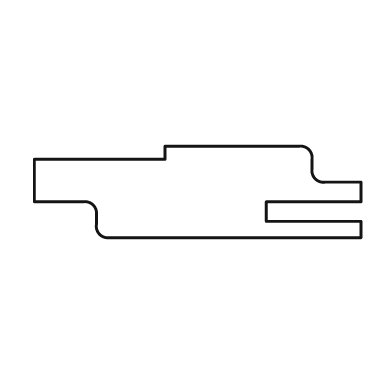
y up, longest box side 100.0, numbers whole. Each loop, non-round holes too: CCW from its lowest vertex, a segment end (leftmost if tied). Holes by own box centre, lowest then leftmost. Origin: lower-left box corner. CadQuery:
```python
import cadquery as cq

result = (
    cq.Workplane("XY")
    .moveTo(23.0, 0.0)
    .lineTo(100.0, 0.0)
    .lineTo(100.0, 5.0)
    .lineTo(71.0, 5.0)
    .lineTo(71.0, 11.0)
    .lineTo(100.0, 11.0)
    .lineTo(100.0, 17.0)
    .lineTo(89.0, 17.0)
    .threePointArc((86.0, 18.0), (85.0, 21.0))
    .lineTo(85.0, 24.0)
    .threePointArc((84.0, 27.0), (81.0, 28.0))
    .lineTo(40.0, 28.0)
    .lineTo(40.0, 24.0)
    .lineTo(0.0, 24.0)
    .lineTo(0.0, 11.0)
    .lineTo(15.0, 11.0)
    .threePointArc((18.0, 10.0), (19.0, 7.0))
    .lineTo(19.0, 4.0)
    .threePointArc((20.0, 1.0), (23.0, 0.0))
    .close()
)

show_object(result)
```